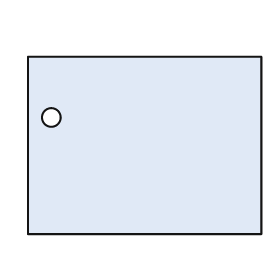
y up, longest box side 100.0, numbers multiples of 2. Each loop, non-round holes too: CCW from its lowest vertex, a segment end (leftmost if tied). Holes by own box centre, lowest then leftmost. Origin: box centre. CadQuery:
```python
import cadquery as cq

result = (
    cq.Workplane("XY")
    .moveTo(-50.0, -38.0)
    .lineTo(50.0, -38.0)
    .lineTo(50.0, 38.0)
    .lineTo(-50.0, 38.0)
    .close()
    .moveTo(-40.0, 12.0)
    .circle(4.0)
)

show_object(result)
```